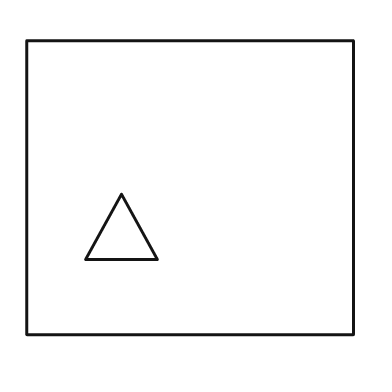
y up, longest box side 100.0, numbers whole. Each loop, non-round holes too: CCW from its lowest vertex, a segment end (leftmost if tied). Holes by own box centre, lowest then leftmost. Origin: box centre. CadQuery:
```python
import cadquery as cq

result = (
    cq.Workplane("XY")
    .moveTo(-50.0, -45.0)
    .lineTo(50.0, -45.0)
    .lineTo(50.0, 45.0)
    .lineTo(-50.0, 45.0)
    .close()
    .moveTo(-32.0, -22.0)
    .lineTo(-10.0, -22.0)
    .lineTo(-21.0, -2.0)
    .close()
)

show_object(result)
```